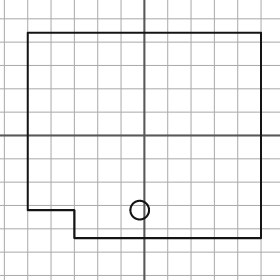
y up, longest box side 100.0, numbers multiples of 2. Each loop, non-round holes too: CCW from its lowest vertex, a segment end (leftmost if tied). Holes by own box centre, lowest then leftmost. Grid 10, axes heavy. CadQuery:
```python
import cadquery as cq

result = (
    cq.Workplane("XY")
    .moveTo(-30.0, -44.0)
    .lineTo(50.0, -44.0)
    .lineTo(50.0, 44.0)
    .lineTo(-50.0, 44.0)
    .lineTo(-50.0, -32.0)
    .lineTo(-30.0, -32.0)
    .close()
    .moveTo(-2.0, -32.0)
    .circle(4.0)
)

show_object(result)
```